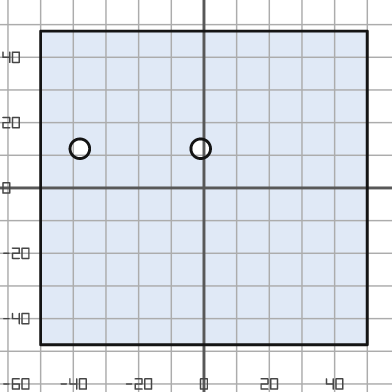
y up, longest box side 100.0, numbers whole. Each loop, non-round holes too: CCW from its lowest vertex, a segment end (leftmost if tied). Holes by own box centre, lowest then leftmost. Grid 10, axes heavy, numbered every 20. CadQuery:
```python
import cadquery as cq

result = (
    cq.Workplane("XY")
    .moveTo(-50.0, -48.0)
    .lineTo(50.0, -48.0)
    .lineTo(50.0, 48.0)
    .lineTo(-50.0, 48.0)
    .close()
    .moveTo(-38.0, 12.0)
    .circle(3.0)
    .moveTo(-1.0, 12.0)
    .circle(3.0)
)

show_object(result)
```